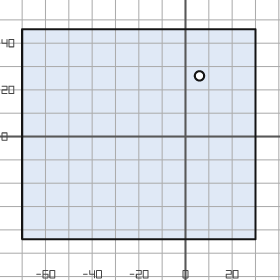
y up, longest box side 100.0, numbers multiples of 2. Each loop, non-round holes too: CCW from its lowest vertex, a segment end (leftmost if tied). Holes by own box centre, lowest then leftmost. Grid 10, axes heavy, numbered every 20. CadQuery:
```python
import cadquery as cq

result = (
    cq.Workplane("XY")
    .moveTo(-70.0, -44.0)
    .lineTo(30.0, -44.0)
    .lineTo(30.0, 46.0)
    .lineTo(-70.0, 46.0)
    .close()
    .moveTo(6.0, 26.0)
    .circle(2.0)
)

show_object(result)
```